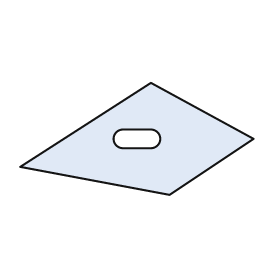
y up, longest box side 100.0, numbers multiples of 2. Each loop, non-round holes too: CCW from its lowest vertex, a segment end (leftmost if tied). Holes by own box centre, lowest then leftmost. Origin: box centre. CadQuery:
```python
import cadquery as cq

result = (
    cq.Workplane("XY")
    .moveTo(14.0, -24.0)
    .lineTo(50.0, 0.0)
    .lineTo(6.0, 24.0)
    .lineTo(-50.0, -12.0)
    .close()
    .moveTo(-6.0, -4.0)
    .lineTo(6.0, -4.0)
    .threePointArc((10.0, 0.0), (6.0, 4.0))
    .lineTo(-6.0, 4.0)
    .threePointArc((-10.0, 0.0), (-6.0, -4.0))
    .close()
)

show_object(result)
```